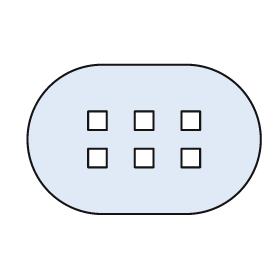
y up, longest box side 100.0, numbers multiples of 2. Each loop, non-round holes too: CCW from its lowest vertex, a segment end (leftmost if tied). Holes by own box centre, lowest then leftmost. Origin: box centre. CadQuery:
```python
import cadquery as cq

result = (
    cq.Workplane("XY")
    .moveTo(-18.0, -32.0)
    .lineTo(18.0, -32.0)
    .threePointArc((50.0, 0.0), (18.0, 32.0))
    .lineTo(-18.0, 32.0)
    .threePointArc((-50.0, 0.0), (-18.0, -32.0))
    .close()
    .moveTo(-24.0, -12.0)
    .lineTo(-16.0, -12.0)
    .lineTo(-16.0, -4.0)
    .lineTo(-24.0, -4.0)
    .close()
    .moveTo(-4.0, -12.0)
    .lineTo(4.0, -12.0)
    .lineTo(4.0, -4.0)
    .lineTo(-4.0, -4.0)
    .close()
    .moveTo(16.0, -12.0)
    .lineTo(24.0, -12.0)
    .lineTo(24.0, -4.0)
    .lineTo(16.0, -4.0)
    .close()
    .moveTo(-24.0, 4.0)
    .lineTo(-16.0, 4.0)
    .lineTo(-16.0, 12.0)
    .lineTo(-24.0, 12.0)
    .close()
    .moveTo(-4.0, 4.0)
    .lineTo(4.0, 4.0)
    .lineTo(4.0, 12.0)
    .lineTo(-4.0, 12.0)
    .close()
    .moveTo(16.0, 4.0)
    .lineTo(24.0, 4.0)
    .lineTo(24.0, 12.0)
    .lineTo(16.0, 12.0)
    .close()
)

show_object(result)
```